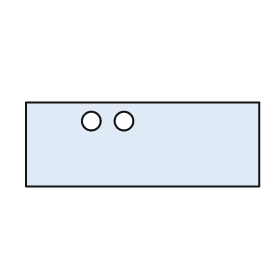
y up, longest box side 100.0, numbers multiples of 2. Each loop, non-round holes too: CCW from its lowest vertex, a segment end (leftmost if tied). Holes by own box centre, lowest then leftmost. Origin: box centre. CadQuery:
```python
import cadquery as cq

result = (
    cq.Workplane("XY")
    .moveTo(-50.0, -18.0)
    .lineTo(50.0, -18.0)
    .lineTo(50.0, 18.0)
    .lineTo(-50.0, 18.0)
    .close()
    .moveTo(-22.0, 10.0)
    .circle(4.0)
    .moveTo(-8.0, 10.0)
    .circle(4.0)
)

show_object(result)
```